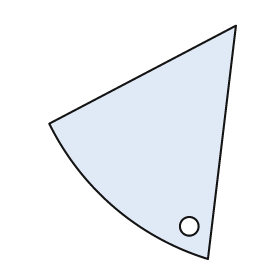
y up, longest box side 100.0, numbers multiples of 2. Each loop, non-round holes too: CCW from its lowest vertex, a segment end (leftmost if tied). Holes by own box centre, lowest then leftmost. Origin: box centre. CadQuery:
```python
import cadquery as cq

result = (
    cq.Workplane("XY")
    .moveTo(28.0, -50.0)
    .lineTo(40.0, 50.0)
    .lineTo(-40.0, 8.0)
    .threePointArc((-12.0, -28.0), (28.0, -50.0))
    .close()
    .moveTo(20.0, -36.0)
    .circle(4.0)
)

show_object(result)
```